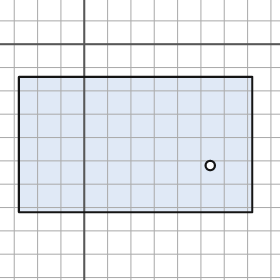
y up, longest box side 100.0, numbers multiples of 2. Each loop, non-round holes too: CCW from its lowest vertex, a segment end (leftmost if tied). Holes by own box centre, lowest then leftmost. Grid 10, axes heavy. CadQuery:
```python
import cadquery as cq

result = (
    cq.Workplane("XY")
    .moveTo(-28.0, -72.0)
    .lineTo(72.0, -72.0)
    .lineTo(72.0, -14.0)
    .lineTo(-28.0, -14.0)
    .close()
    .moveTo(54.0, -52.0)
    .circle(2.0)
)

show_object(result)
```